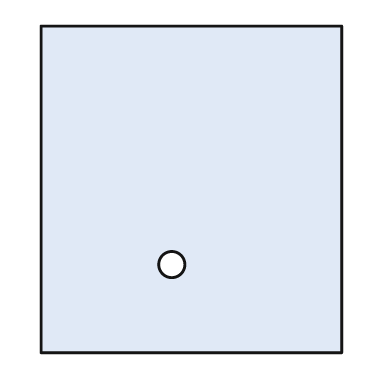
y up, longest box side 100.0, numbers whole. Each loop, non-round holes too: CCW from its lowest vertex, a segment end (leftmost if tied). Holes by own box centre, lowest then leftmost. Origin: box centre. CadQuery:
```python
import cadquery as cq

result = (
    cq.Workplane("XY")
    .moveTo(-46.0, -50.0)
    .lineTo(46.0, -50.0)
    .lineTo(46.0, 50.0)
    .lineTo(-46.0, 50.0)
    .close()
    .moveTo(-6.0, -23.0)
    .circle(4.0)
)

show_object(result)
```